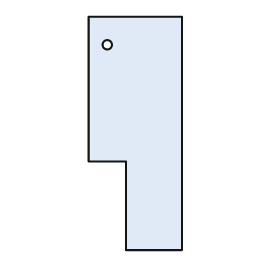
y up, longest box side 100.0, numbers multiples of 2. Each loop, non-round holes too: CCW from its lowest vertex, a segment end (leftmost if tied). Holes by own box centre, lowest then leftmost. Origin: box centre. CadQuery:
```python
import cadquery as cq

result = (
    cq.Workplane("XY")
    .moveTo(-4.0, -50.0)
    .lineTo(20.0, -50.0)
    .lineTo(20.0, 50.0)
    .lineTo(-20.0, 50.0)
    .lineTo(-20.0, -12.0)
    .lineTo(-4.0, -12.0)
    .close()
    .moveTo(-12.0, 38.0)
    .circle(2.0)
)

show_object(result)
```